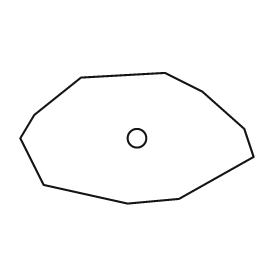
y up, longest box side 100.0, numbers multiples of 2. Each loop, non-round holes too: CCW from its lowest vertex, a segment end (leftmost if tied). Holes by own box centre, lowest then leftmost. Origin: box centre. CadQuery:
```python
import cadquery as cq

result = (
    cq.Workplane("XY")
    .moveTo(-4.0, -28.0)
    .lineTo(18.0, -26.0)
    .lineTo(50.0, -8.0)
    .lineTo(46.0, 4.0)
    .lineTo(28.0, 20.0)
    .lineTo(12.0, 28.0)
    .lineTo(-24.0, 26.0)
    .lineTo(-44.0, 10.0)
    .lineTo(-50.0, 0.0)
    .lineTo(-40.0, -20.0)
    .close()
    .moveTo(0.0, 0.0)
    .circle(4.0)
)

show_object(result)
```